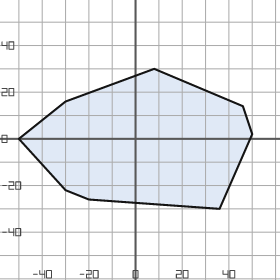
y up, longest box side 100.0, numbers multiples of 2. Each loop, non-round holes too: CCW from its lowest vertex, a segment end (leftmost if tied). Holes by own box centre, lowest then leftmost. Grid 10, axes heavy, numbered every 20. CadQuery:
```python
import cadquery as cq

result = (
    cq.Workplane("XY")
    .moveTo(36.0, -30.0)
    .lineTo(50.0, 2.0)
    .lineTo(46.0, 14.0)
    .lineTo(8.0, 30.0)
    .lineTo(-30.0, 16.0)
    .lineTo(-50.0, 0.0)
    .lineTo(-30.0, -22.0)
    .lineTo(-20.0, -26.0)
    .close()
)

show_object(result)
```